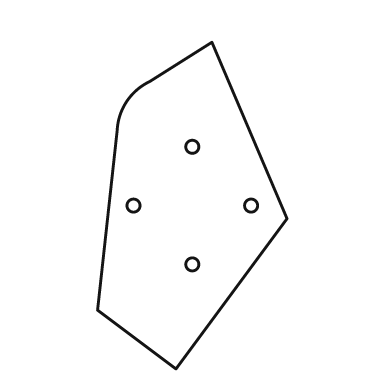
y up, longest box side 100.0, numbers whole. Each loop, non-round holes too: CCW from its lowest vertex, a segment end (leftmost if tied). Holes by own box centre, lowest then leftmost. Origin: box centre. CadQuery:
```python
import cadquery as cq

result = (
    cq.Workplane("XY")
    .moveTo(-5.0, -50.0)
    .lineTo(29.0, -4.0)
    .lineTo(6.0, 50.0)
    .lineTo(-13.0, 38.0)
    .threePointArc((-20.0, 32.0), (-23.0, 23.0))
    .lineTo(-29.0, -32.0)
    .close()
    .moveTo(0.0, -18.0)
    .circle(2.0)
    .moveTo(-18.0, 0.0)
    .circle(2.0)
    .moveTo(18.0, 0.0)
    .circle(2.0)
    .moveTo(0.0, 18.0)
    .circle(2.0)
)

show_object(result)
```